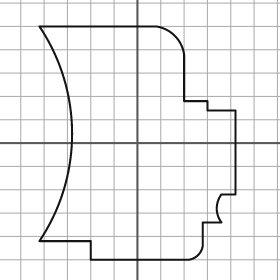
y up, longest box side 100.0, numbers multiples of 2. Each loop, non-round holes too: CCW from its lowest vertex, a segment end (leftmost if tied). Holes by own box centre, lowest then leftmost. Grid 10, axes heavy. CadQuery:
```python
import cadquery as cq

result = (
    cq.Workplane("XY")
    .moveTo(-20.0, -50.0)
    .lineTo(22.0, -50.0)
    .threePointArc((26.0, -48.0), (28.0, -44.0))
    .lineTo(28.0, -34.0)
    .lineTo(36.0, -34.0)
    .threePointArc((34.0, -28.0), (36.0, -22.0))
    .lineTo(42.0, -22.0)
    .lineTo(42.0, 14.0)
    .lineTo(30.0, 14.0)
    .lineTo(30.0, 18.0)
    .lineTo(20.0, 18.0)
    .lineTo(20.0, 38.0)
    .threePointArc((16.0, 46.0), (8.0, 50.0))
    .lineTo(-42.0, 50.0)
    .threePointArc((-28.0, 4.0), (-42.0, -42.0))
    .lineTo(-20.0, -42.0)
    .close()
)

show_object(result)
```